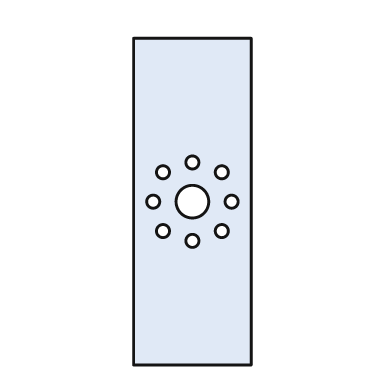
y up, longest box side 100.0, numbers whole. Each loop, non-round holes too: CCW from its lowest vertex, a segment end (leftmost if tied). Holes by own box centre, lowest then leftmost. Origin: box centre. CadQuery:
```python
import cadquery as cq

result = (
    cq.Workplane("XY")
    .moveTo(-18.0, -50.0)
    .lineTo(18.0, -50.0)
    .lineTo(18.0, 50.0)
    .lineTo(-18.0, 50.0)
    .close()
    .moveTo(0.0, -12.0)
    .circle(2.0)
    .moveTo(-9.0, -9.0)
    .circle(2.0)
    .moveTo(9.0, -9.0)
    .circle(2.0)
    .moveTo(-12.0, 0.0)
    .circle(2.0)
    .moveTo(0.0, 0.0)
    .circle(5.0)
    .moveTo(12.0, 0.0)
    .circle(2.0)
    .moveTo(-9.0, 9.0)
    .circle(2.0)
    .moveTo(9.0, 9.0)
    .circle(2.0)
    .moveTo(0.0, 12.0)
    .circle(2.0)
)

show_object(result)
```